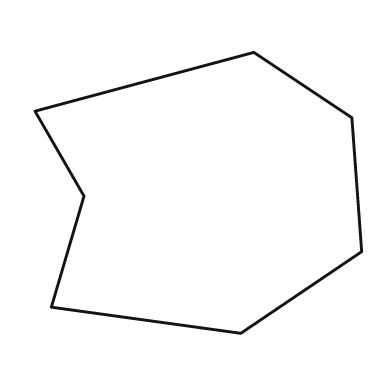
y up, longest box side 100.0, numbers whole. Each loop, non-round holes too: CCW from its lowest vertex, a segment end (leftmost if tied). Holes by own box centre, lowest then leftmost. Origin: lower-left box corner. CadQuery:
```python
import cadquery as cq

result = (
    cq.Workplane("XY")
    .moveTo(63.0, 0.0)
    .lineTo(100.0, 25.0)
    .lineTo(97.0, 66.0)
    .lineTo(67.0, 86.0)
    .lineTo(0.0, 68.0)
    .lineTo(15.0, 42.0)
    .lineTo(5.0, 8.0)
    .close()
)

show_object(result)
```